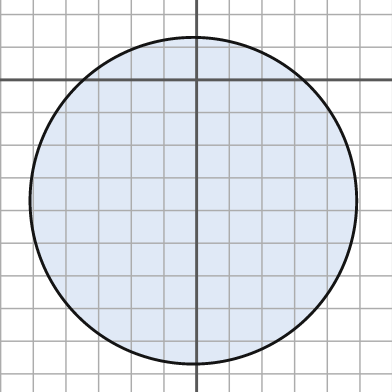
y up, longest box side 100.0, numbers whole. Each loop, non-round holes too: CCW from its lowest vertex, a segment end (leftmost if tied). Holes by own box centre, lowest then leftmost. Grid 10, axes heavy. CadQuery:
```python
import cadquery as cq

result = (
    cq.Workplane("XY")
    .moveTo(-1.0, -37.0)
    .circle(50.0)
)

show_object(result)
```